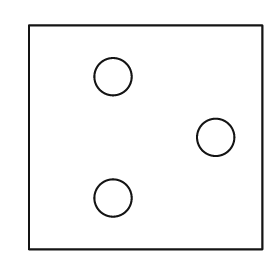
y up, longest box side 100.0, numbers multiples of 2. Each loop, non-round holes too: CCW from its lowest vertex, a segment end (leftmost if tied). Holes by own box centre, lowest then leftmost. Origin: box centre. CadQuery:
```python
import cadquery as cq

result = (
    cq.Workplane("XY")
    .moveTo(-50.0, -48.0)
    .lineTo(50.0, -48.0)
    .lineTo(50.0, 48.0)
    .lineTo(-50.0, 48.0)
    .close()
    .moveTo(-14.0, -26.0)
    .circle(8.0)
    .moveTo(30.0, 0.0)
    .circle(8.0)
    .moveTo(-14.0, 26.0)
    .circle(8.0)
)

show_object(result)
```